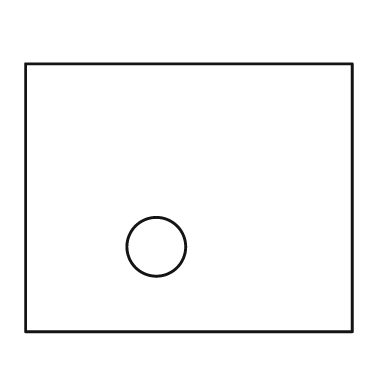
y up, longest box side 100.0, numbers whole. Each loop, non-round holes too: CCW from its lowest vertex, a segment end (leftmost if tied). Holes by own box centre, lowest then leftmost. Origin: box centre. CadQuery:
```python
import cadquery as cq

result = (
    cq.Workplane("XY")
    .moveTo(-50.0, -41.0)
    .lineTo(50.0, -41.0)
    .lineTo(50.0, 41.0)
    .lineTo(-50.0, 41.0)
    .close()
    .moveTo(-10.0, -15.0)
    .circle(9.0)
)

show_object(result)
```